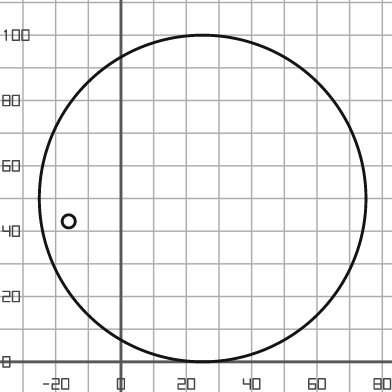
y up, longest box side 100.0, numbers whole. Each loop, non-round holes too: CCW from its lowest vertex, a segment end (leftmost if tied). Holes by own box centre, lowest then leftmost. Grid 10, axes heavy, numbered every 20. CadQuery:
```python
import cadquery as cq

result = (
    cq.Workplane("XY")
    .moveTo(25.0, 50.0)
    .circle(50.0)
    .moveTo(-16.0, 43.0)
    .circle(2.0)
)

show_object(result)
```